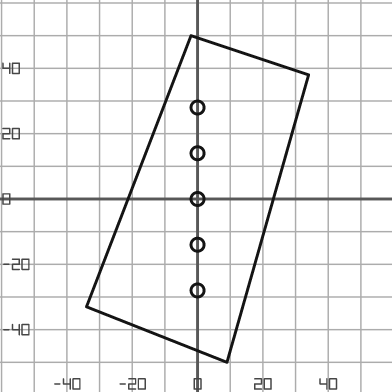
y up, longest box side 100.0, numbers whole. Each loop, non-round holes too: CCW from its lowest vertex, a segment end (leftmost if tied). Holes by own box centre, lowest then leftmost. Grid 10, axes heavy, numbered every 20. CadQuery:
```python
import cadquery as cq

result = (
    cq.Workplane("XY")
    .moveTo(9.0, -50.0)
    .lineTo(34.0, 38.0)
    .lineTo(-2.0, 50.0)
    .lineTo(-34.0, -33.0)
    .close()
    .moveTo(0.0, -28.0)
    .circle(2.0)
    .moveTo(0.0, -14.0)
    .circle(2.0)
    .moveTo(0.0, 0.0)
    .circle(2.0)
    .moveTo(0.0, 14.0)
    .circle(2.0)
    .moveTo(0.0, 28.0)
    .circle(2.0)
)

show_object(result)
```